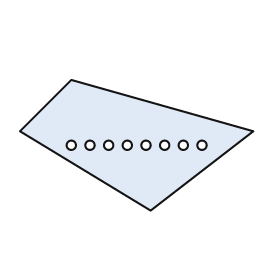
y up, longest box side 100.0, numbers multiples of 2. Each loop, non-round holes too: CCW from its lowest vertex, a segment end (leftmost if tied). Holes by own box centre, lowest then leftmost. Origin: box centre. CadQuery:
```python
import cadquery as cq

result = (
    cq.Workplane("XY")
    .moveTo(6.0, -28.0)
    .lineTo(50.0, 6.0)
    .lineTo(-28.0, 28.0)
    .lineTo(-50.0, 6.0)
    .close()
    .moveTo(-28.0, 0.0)
    .circle(2.0)
    .moveTo(-20.0, 0.0)
    .circle(2.0)
    .moveTo(-12.0, 0.0)
    .circle(2.0)
    .moveTo(-4.0, 0.0)
    .circle(2.0)
    .moveTo(4.0, 0.0)
    .circle(2.0)
    .moveTo(12.0, 0.0)
    .circle(2.0)
    .moveTo(20.0, 0.0)
    .circle(2.0)
    .moveTo(28.0, 0.0)
    .circle(2.0)
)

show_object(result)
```